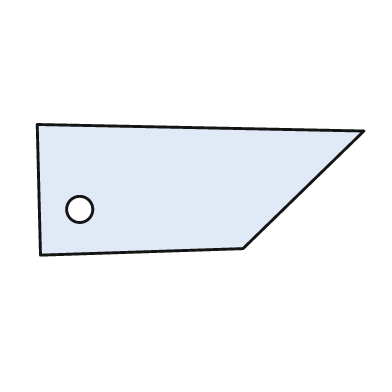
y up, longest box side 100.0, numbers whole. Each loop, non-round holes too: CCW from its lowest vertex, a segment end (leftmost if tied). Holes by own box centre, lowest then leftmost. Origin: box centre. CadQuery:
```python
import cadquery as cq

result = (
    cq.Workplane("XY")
    .moveTo(-49.0, -20.0)
    .lineTo(13.0, -18.0)
    .lineTo(50.0, 18.0)
    .lineTo(-50.0, 20.0)
    .close()
    .moveTo(-37.0, -6.0)
    .circle(4.0)
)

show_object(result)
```